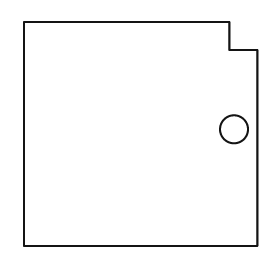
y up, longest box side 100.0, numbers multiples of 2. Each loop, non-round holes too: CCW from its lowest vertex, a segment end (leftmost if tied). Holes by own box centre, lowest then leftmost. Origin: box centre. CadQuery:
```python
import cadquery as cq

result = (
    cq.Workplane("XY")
    .moveTo(-50.0, -48.0)
    .lineTo(50.0, -48.0)
    .lineTo(50.0, 36.0)
    .lineTo(38.0, 36.0)
    .lineTo(38.0, 48.0)
    .lineTo(-50.0, 48.0)
    .close()
    .moveTo(40.0, 2.0)
    .circle(6.0)
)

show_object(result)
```